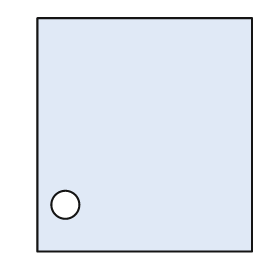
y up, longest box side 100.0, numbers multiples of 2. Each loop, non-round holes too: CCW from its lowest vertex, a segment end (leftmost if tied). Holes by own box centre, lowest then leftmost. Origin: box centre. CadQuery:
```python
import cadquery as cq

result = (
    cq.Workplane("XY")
    .moveTo(-46.0, -50.0)
    .lineTo(46.0, -50.0)
    .lineTo(46.0, 50.0)
    .lineTo(-46.0, 50.0)
    .close()
    .moveTo(-34.0, -30.0)
    .circle(6.0)
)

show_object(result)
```